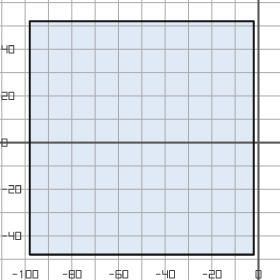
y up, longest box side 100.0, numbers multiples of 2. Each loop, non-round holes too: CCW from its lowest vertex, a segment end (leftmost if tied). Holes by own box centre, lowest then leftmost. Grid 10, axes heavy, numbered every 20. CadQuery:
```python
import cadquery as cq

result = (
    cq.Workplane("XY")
    .moveTo(-98.0, -48.0)
    .lineTo(-2.0, -48.0)
    .lineTo(-2.0, 52.0)
    .lineTo(-98.0, 52.0)
    .close()
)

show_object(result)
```